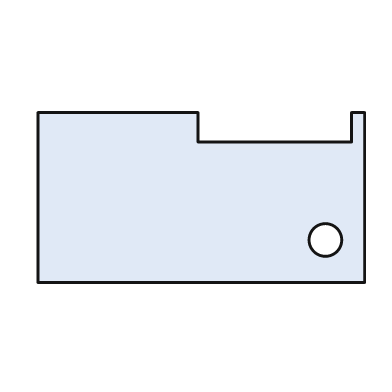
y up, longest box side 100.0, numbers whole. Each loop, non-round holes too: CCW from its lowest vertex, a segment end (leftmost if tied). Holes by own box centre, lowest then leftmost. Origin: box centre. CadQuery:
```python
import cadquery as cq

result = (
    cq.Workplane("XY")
    .moveTo(-50.0, -26.0)
    .lineTo(50.0, -26.0)
    .lineTo(50.0, 26.0)
    .lineTo(46.0, 26.0)
    .lineTo(46.0, 17.0)
    .lineTo(-1.0, 17.0)
    .lineTo(-1.0, 26.0)
    .lineTo(-50.0, 26.0)
    .close()
    .moveTo(38.0, -13.0)
    .circle(5.0)
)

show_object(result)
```